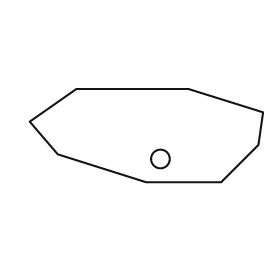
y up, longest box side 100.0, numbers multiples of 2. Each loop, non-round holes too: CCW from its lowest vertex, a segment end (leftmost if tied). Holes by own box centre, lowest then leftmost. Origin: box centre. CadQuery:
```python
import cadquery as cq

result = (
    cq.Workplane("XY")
    .moveTo(0.0, -20.0)
    .lineTo(32.0, -20.0)
    .lineTo(48.0, -4.0)
    .lineTo(50.0, 10.0)
    .lineTo(18.0, 20.0)
    .lineTo(-30.0, 20.0)
    .lineTo(-50.0, 6.0)
    .lineTo(-38.0, -8.0)
    .close()
    .moveTo(6.0, -10.0)
    .circle(4.0)
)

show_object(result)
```